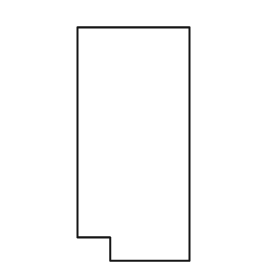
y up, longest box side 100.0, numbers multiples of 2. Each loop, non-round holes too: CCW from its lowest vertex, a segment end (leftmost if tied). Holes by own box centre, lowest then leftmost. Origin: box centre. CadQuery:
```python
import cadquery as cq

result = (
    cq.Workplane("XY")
    .moveTo(-10.0, -50.0)
    .lineTo(24.0, -50.0)
    .lineTo(24.0, 50.0)
    .lineTo(-24.0, 50.0)
    .lineTo(-24.0, -40.0)
    .lineTo(-10.0, -40.0)
    .close()
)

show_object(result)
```